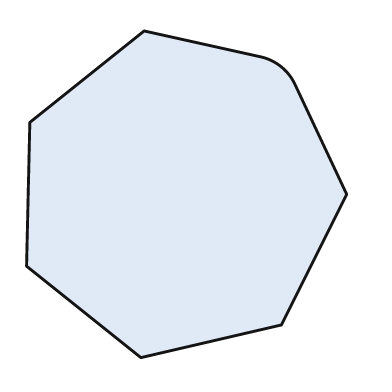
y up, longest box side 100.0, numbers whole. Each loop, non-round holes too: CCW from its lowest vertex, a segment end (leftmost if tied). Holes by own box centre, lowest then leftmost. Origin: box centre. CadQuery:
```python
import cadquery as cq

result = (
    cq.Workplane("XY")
    .moveTo(-14.0, -50.0)
    .lineTo(29.0, -40.0)
    .lineTo(49.0, 0.0)
    .lineTo(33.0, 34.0)
    .threePointArc((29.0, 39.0), (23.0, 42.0))
    .lineTo(-13.0, 50.0)
    .lineTo(-48.0, 22.0)
    .lineTo(-49.0, -22.0)
    .close()
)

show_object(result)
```